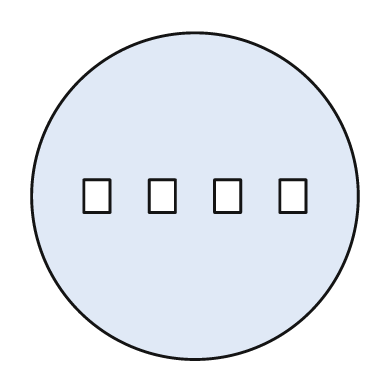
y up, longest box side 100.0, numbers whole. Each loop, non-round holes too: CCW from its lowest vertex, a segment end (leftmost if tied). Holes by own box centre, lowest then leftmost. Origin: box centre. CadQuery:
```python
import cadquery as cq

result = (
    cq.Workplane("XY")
    .moveTo(0.0, 0.0)
    .circle(50.0)
    .moveTo(-34.0, -5.0)
    .lineTo(-26.0, -5.0)
    .lineTo(-26.0, 5.0)
    .lineTo(-34.0, 5.0)
    .close()
    .moveTo(-14.0, -5.0)
    .lineTo(-6.0, -5.0)
    .lineTo(-6.0, 5.0)
    .lineTo(-14.0, 5.0)
    .close()
    .moveTo(6.0, -5.0)
    .lineTo(14.0, -5.0)
    .lineTo(14.0, 5.0)
    .lineTo(6.0, 5.0)
    .close()
    .moveTo(26.0, -5.0)
    .lineTo(34.0, -5.0)
    .lineTo(34.0, 5.0)
    .lineTo(26.0, 5.0)
    .close()
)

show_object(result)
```